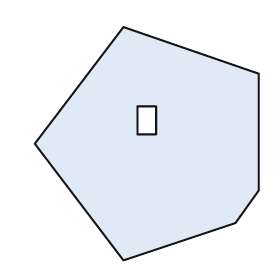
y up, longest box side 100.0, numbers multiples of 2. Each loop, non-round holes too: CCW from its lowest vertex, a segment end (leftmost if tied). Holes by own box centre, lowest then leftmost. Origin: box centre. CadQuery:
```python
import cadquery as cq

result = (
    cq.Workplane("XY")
    .moveTo(-10.0, -50.0)
    .lineTo(38.0, -34.0)
    .lineTo(48.0, -20.0)
    .lineTo(48.0, 30.0)
    .lineTo(-10.0, 50.0)
    .lineTo(-48.0, 0.0)
    .close()
    .moveTo(-4.0, 4.0)
    .lineTo(4.0, 4.0)
    .lineTo(4.0, 16.0)
    .lineTo(-4.0, 16.0)
    .close()
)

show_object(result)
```